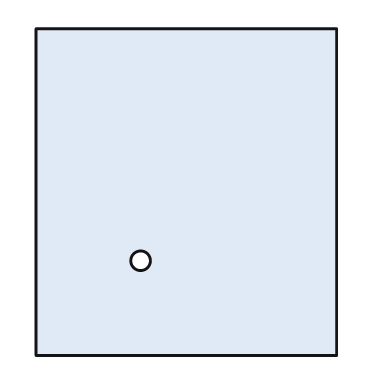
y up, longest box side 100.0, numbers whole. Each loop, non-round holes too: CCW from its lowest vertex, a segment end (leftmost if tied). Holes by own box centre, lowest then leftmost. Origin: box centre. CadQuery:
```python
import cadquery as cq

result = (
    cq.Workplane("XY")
    .moveTo(-46.0, -50.0)
    .lineTo(46.0, -50.0)
    .lineTo(46.0, 50.0)
    .lineTo(-46.0, 50.0)
    .close()
    .moveTo(-14.0, -21.0)
    .circle(3.0)
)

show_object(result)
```